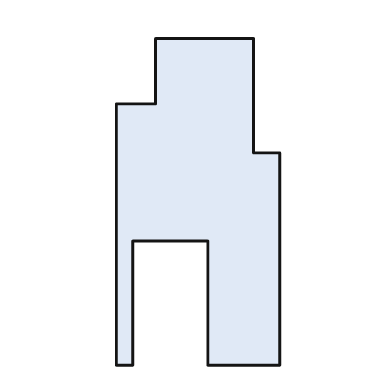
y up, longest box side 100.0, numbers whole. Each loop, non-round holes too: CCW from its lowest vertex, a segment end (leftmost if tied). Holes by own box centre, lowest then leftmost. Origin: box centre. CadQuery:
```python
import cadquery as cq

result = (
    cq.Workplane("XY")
    .moveTo(-25.0, -50.0)
    .lineTo(-20.0, -50.0)
    .lineTo(-20.0, -12.0)
    .lineTo(3.0, -12.0)
    .lineTo(3.0, -50.0)
    .lineTo(25.0, -50.0)
    .lineTo(25.0, 15.0)
    .lineTo(17.0, 15.0)
    .lineTo(17.0, 50.0)
    .lineTo(-13.0, 50.0)
    .lineTo(-13.0, 30.0)
    .lineTo(-25.0, 30.0)
    .close()
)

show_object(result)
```